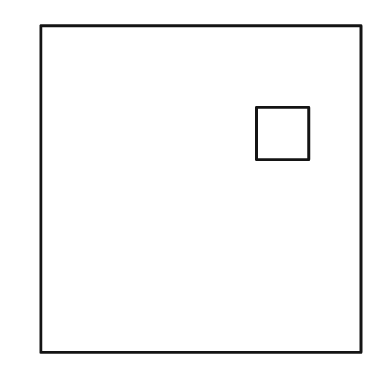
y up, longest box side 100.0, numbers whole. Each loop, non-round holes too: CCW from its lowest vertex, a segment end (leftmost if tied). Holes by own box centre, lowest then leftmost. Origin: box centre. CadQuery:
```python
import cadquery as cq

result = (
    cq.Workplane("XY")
    .moveTo(-49.0, -50.0)
    .lineTo(49.0, -50.0)
    .lineTo(49.0, 50.0)
    .lineTo(-49.0, 50.0)
    .close()
    .moveTo(17.0, 9.0)
    .lineTo(33.0, 9.0)
    .lineTo(33.0, 25.0)
    .lineTo(17.0, 25.0)
    .close()
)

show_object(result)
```